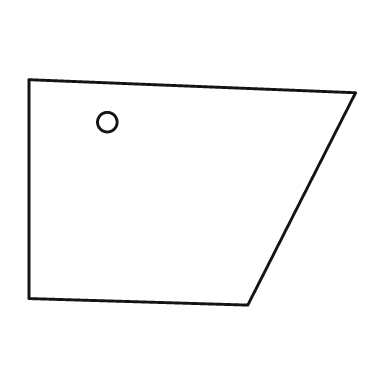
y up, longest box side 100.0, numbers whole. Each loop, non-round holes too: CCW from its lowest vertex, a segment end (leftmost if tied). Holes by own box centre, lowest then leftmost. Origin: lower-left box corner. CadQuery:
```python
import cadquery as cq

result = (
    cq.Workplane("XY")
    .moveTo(67.0, 0.0)
    .lineTo(100.0, 65.0)
    .lineTo(0.0, 69.0)
    .lineTo(0.0, 2.0)
    .close()
    .moveTo(24.0, 56.0)
    .circle(3.0)
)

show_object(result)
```